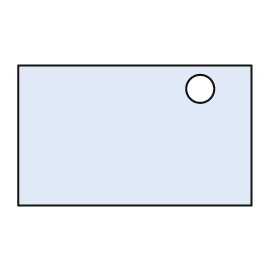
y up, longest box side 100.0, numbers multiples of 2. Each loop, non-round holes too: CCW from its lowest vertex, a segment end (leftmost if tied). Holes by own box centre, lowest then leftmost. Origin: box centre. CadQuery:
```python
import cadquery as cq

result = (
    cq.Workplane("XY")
    .moveTo(-50.0, -30.0)
    .lineTo(50.0, -30.0)
    .lineTo(50.0, 30.0)
    .lineTo(-50.0, 30.0)
    .close()
    .moveTo(28.0, 20.0)
    .circle(6.0)
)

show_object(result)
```